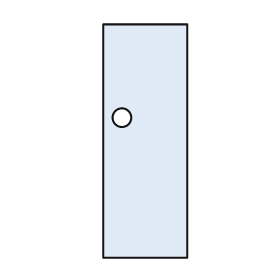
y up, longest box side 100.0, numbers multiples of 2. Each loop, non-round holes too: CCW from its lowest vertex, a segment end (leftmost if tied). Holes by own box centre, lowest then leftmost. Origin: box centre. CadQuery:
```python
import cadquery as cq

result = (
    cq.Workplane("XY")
    .moveTo(-18.0, -50.0)
    .lineTo(18.0, -50.0)
    .lineTo(18.0, 50.0)
    .lineTo(-18.0, 50.0)
    .close()
    .moveTo(-10.0, 10.0)
    .circle(4.0)
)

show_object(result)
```